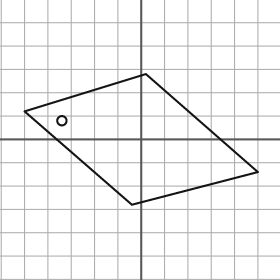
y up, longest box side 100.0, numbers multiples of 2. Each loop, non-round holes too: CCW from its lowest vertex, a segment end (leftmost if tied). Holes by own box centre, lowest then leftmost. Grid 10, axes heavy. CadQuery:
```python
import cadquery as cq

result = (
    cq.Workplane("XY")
    .moveTo(-4.0, -28.0)
    .lineTo(50.0, -14.0)
    .lineTo(2.0, 28.0)
    .lineTo(-50.0, 12.0)
    .close()
    .moveTo(-34.0, 8.0)
    .circle(2.0)
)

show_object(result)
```